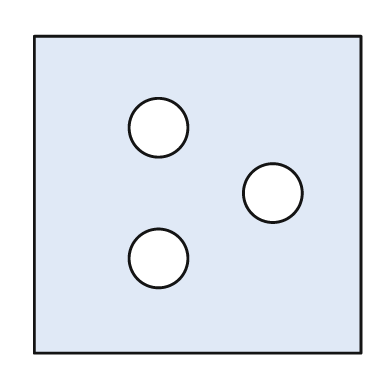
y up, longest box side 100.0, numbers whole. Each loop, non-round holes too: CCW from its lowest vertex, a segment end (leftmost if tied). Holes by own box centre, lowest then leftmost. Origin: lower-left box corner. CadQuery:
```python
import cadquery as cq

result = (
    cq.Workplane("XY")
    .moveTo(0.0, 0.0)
    .lineTo(100.0, 0.0)
    .lineTo(100.0, 97.0)
    .lineTo(0.0, 97.0)
    .close()
    .moveTo(38.0, 29.0)
    .circle(9.0)
    .moveTo(73.0, 49.0)
    .circle(9.0)
    .moveTo(38.0, 69.0)
    .circle(9.0)
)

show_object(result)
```